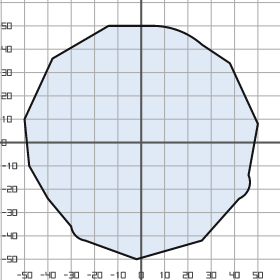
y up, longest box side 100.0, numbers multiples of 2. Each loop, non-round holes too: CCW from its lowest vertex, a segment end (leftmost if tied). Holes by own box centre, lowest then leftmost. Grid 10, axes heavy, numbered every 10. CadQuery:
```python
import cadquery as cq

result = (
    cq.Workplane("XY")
    .moveTo(-2.0, -50.0)
    .lineTo(26.0, -42.0)
    .lineTo(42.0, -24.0)
    .threePointArc((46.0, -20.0), (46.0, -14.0))
    .lineTo(50.0, 8.0)
    .lineTo(38.0, 34.0)
    .lineTo(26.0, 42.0)
    .threePointArc((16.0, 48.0), (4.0, 50.0))
    .lineTo(-14.0, 50.0)
    .lineTo(-38.0, 36.0)
    .lineTo(-50.0, 10.0)
    .lineTo(-48.0, -10.0)
    .lineTo(-40.0, -24.0)
    .lineTo(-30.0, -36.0)
    .threePointArc((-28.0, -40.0), (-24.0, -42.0))
    .close()
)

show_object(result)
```